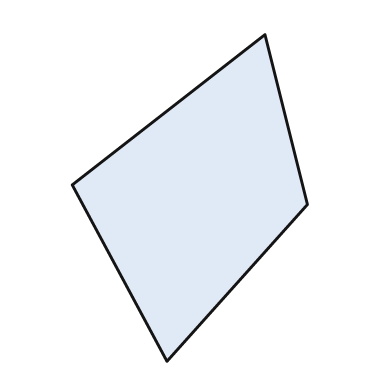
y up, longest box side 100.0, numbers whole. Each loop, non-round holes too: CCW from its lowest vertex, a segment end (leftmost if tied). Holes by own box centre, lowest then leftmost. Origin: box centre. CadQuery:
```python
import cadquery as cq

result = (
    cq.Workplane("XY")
    .moveTo(-7.0, -50.0)
    .lineTo(36.0, -2.0)
    .lineTo(23.0, 50.0)
    .lineTo(-36.0, 4.0)
    .close()
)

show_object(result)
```